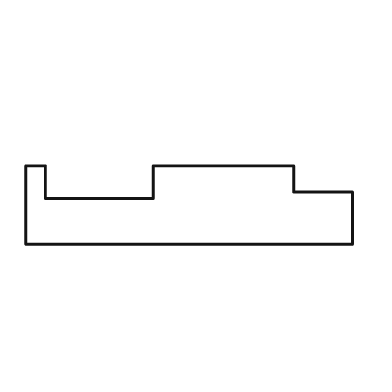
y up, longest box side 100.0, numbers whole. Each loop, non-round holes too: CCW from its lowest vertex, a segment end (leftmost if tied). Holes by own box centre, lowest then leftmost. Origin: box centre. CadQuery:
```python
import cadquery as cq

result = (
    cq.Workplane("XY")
    .moveTo(-50.0, -12.0)
    .lineTo(50.0, -12.0)
    .lineTo(50.0, 4.0)
    .lineTo(32.0, 4.0)
    .lineTo(32.0, 12.0)
    .lineTo(-11.0, 12.0)
    .lineTo(-11.0, 2.0)
    .lineTo(-44.0, 2.0)
    .lineTo(-44.0, 12.0)
    .lineTo(-50.0, 12.0)
    .close()
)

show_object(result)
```